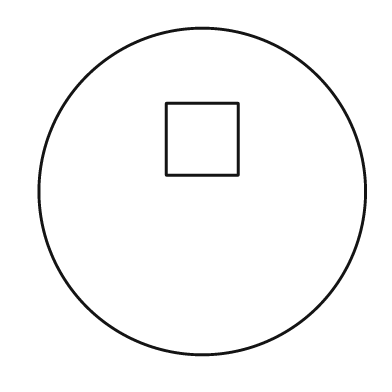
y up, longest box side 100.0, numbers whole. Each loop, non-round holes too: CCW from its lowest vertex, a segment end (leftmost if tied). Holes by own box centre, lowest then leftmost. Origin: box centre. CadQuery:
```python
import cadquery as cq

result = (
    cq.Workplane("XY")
    .moveTo(0.0, 0.0)
    .circle(50.0)
    .moveTo(-11.0, 5.0)
    .lineTo(11.0, 5.0)
    .lineTo(11.0, 27.0)
    .lineTo(-11.0, 27.0)
    .close()
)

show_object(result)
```